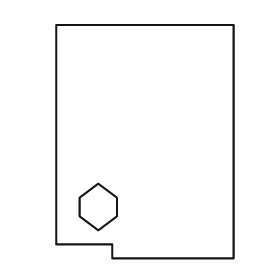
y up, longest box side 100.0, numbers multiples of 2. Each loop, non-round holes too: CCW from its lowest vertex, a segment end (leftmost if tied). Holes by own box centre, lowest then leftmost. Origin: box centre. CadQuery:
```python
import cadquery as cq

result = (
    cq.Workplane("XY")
    .moveTo(-14.0, -50.0)
    .lineTo(38.0, -50.0)
    .lineTo(38.0, 50.0)
    .lineTo(-38.0, 50.0)
    .lineTo(-38.0, -44.0)
    .lineTo(-14.0, -44.0)
    .close()
    .moveTo(-20.0, -38.0)
    .lineTo(-12.0, -32.0)
    .lineTo(-12.0, -24.0)
    .lineTo(-20.0, -18.0)
    .lineTo(-28.0, -24.0)
    .lineTo(-28.0, -32.0)
    .close()
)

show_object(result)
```